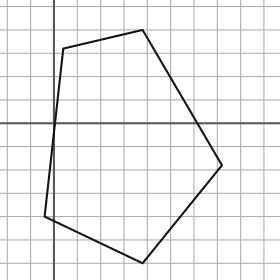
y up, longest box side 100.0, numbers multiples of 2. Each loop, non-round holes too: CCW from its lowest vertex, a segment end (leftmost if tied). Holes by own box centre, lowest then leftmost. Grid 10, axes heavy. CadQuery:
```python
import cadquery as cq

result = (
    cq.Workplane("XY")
    .moveTo(38.0, -60.0)
    .lineTo(72.0, -18.0)
    .lineTo(38.0, 40.0)
    .lineTo(4.0, 32.0)
    .lineTo(-4.0, -40.0)
    .close()
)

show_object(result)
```